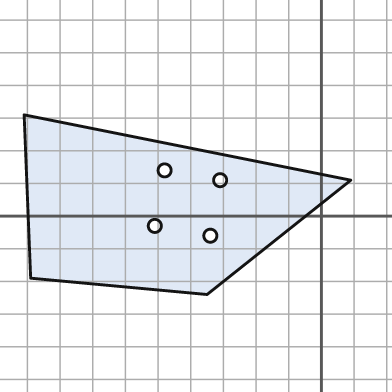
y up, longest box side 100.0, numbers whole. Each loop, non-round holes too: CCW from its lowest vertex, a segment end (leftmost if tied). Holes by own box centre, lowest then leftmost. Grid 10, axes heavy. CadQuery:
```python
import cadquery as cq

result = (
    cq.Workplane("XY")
    .moveTo(-35.0, -24.0)
    .lineTo(9.0, 11.0)
    .lineTo(-91.0, 31.0)
    .lineTo(-89.0, -19.0)
    .close()
    .moveTo(-34.0, -6.0)
    .circle(2.0)
    .moveTo(-51.0, -3.0)
    .circle(2.0)
    .moveTo(-31.0, 11.0)
    .circle(2.0)
    .moveTo(-48.0, 14.0)
    .circle(2.0)
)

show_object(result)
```